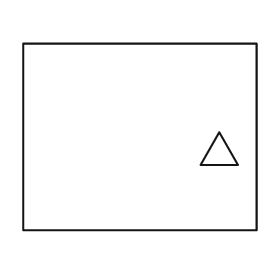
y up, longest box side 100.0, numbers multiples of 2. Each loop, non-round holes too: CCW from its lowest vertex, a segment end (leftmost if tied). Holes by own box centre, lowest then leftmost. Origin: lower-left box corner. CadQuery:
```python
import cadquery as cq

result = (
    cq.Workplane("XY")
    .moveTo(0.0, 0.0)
    .lineTo(100.0, 0.0)
    .lineTo(100.0, 80.0)
    .lineTo(0.0, 80.0)
    .close()
    .moveTo(76.0, 28.0)
    .lineTo(92.0, 28.0)
    .lineTo(84.0, 42.0)
    .close()
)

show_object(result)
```